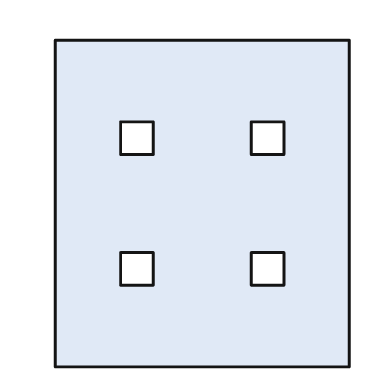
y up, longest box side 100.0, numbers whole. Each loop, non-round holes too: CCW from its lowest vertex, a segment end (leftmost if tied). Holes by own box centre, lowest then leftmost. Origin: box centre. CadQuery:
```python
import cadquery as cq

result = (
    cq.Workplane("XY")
    .moveTo(-45.0, -50.0)
    .lineTo(45.0, -50.0)
    .lineTo(45.0, 50.0)
    .lineTo(-45.0, 50.0)
    .close()
    .moveTo(-25.0, -25.0)
    .lineTo(-15.0, -25.0)
    .lineTo(-15.0, -15.0)
    .lineTo(-25.0, -15.0)
    .close()
    .moveTo(15.0, -25.0)
    .lineTo(25.0, -25.0)
    .lineTo(25.0, -15.0)
    .lineTo(15.0, -15.0)
    .close()
    .moveTo(-25.0, 15.0)
    .lineTo(-15.0, 15.0)
    .lineTo(-15.0, 25.0)
    .lineTo(-25.0, 25.0)
    .close()
    .moveTo(15.0, 15.0)
    .lineTo(25.0, 15.0)
    .lineTo(25.0, 25.0)
    .lineTo(15.0, 25.0)
    .close()
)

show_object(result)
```